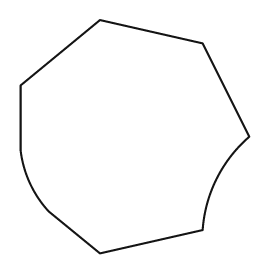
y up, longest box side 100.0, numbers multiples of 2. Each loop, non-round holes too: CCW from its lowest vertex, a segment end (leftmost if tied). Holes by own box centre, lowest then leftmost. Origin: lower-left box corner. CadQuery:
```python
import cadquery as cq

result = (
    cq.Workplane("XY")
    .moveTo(34.0, 0.0)
    .lineTo(78.0, 10.0)
    .threePointArc((84.0, 32.0), (98.0, 50.0))
    .lineTo(78.0, 90.0)
    .lineTo(34.0, 100.0)
    .lineTo(0.0, 72.0)
    .lineTo(0.0, 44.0)
    .threePointArc((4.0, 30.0), (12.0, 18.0))
    .close()
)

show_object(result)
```